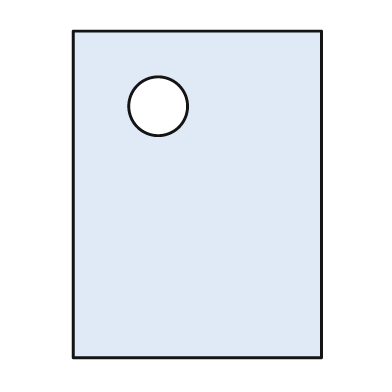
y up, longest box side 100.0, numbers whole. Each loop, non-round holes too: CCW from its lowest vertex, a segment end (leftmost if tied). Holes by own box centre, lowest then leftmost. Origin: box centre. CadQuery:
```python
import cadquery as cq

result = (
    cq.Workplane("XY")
    .moveTo(-38.0, -50.0)
    .lineTo(38.0, -50.0)
    .lineTo(38.0, 50.0)
    .lineTo(-38.0, 50.0)
    .close()
    .moveTo(-12.0, 27.0)
    .circle(9.0)
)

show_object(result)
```